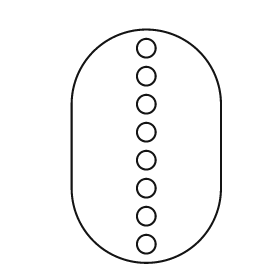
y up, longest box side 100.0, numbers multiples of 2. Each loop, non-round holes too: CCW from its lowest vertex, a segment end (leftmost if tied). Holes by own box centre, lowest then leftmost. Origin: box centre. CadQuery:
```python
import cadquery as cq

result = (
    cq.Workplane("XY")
    .moveTo(-32.0, -18.0)
    .threePointArc((0.0, -50.0), (32.0, -18.0))
    .lineTo(32.0, 18.0)
    .threePointArc((0.0, 50.0), (-32.0, 18.0))
    .close()
    .moveTo(0.0, -42.0)
    .circle(4.0)
    .moveTo(0.0, -30.0)
    .circle(4.0)
    .moveTo(0.0, -18.0)
    .circle(4.0)
    .moveTo(0.0, -6.0)
    .circle(4.0)
    .moveTo(0.0, 6.0)
    .circle(4.0)
    .moveTo(0.0, 18.0)
    .circle(4.0)
    .moveTo(0.0, 30.0)
    .circle(4.0)
    .moveTo(0.0, 42.0)
    .circle(4.0)
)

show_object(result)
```